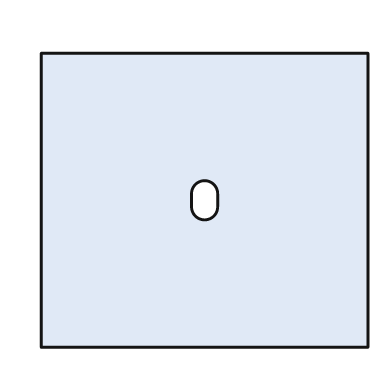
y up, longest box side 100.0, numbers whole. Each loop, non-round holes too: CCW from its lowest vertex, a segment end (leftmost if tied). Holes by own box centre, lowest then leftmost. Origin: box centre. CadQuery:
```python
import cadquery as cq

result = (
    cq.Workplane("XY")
    .moveTo(-50.0, -45.0)
    .lineTo(50.0, -45.0)
    .lineTo(50.0, 45.0)
    .lineTo(-50.0, 45.0)
    .close()
    .moveTo(-4.0, -2.0)
    .threePointArc((0.0, -6.0), (4.0, -2.0))
    .lineTo(4.0, 2.0)
    .threePointArc((0.0, 6.0), (-4.0, 2.0))
    .close()
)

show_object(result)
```